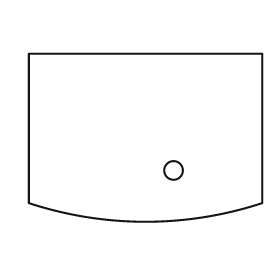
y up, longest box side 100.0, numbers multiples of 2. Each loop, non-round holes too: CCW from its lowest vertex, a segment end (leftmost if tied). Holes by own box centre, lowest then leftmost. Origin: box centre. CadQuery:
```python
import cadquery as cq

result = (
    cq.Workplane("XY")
    .moveTo(-50.0, -28.0)
    .threePointArc((0.0, -36.0), (50.0, -28.0))
    .lineTo(50.0, 36.0)
    .lineTo(-50.0, 36.0)
    .close()
    .moveTo(12.0, -14.0)
    .circle(4.0)
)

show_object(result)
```